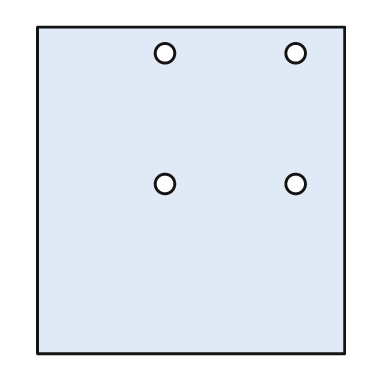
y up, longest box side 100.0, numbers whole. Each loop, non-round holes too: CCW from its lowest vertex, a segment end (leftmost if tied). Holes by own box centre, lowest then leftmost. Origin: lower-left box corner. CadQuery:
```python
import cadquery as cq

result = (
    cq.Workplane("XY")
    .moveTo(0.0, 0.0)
    .lineTo(94.0, 0.0)
    .lineTo(94.0, 100.0)
    .lineTo(0.0, 100.0)
    .close()
    .moveTo(39.0, 52.0)
    .circle(3.0)
    .moveTo(79.0, 52.0)
    .circle(3.0)
    .moveTo(39.0, 92.0)
    .circle(3.0)
    .moveTo(79.0, 92.0)
    .circle(3.0)
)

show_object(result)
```